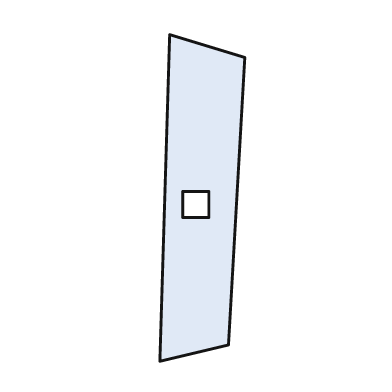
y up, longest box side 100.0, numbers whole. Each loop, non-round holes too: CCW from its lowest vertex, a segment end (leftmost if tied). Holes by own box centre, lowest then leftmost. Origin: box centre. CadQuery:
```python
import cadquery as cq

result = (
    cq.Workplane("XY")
    .moveTo(-13.0, -50.0)
    .lineTo(8.0, -45.0)
    .lineTo(13.0, 43.0)
    .lineTo(-10.0, 50.0)
    .close()
    .moveTo(-6.0, -6.0)
    .lineTo(2.0, -6.0)
    .lineTo(2.0, 2.0)
    .lineTo(-6.0, 2.0)
    .close()
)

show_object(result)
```